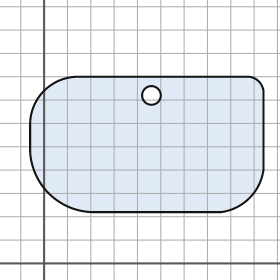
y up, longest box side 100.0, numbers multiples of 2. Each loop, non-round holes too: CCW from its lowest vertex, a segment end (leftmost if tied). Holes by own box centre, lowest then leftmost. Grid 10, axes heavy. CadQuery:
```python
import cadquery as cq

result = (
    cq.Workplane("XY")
    .moveTo(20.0, 22.0)
    .lineTo(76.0, 22.0)
    .threePointArc((88.0, 28.0), (94.0, 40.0))
    .lineTo(94.0, 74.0)
    .threePointArc((92.0, 78.0), (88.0, 80.0))
    .lineTo(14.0, 80.0)
    .threePointArc((0.0, 74.0), (-6.0, 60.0))
    .lineTo(-6.0, 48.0)
    .threePointArc((2.0, 30.0), (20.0, 22.0))
    .close()
    .moveTo(46.0, 72.0)
    .circle(4.0)
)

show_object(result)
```